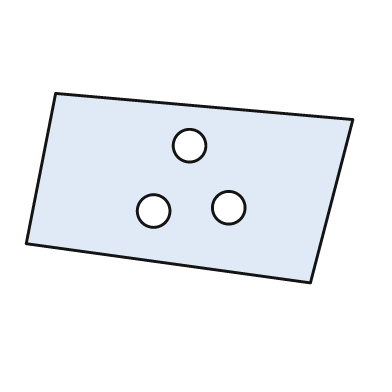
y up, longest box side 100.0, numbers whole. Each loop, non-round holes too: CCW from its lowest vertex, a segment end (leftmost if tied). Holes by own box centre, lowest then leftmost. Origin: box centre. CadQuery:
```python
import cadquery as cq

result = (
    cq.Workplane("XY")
    .moveTo(37.0, -29.0)
    .lineTo(50.0, 21.0)
    .lineTo(-41.0, 29.0)
    .lineTo(-50.0, -17.0)
    .close()
    .moveTo(-11.0, -7.0)
    .circle(5.0)
    .moveTo(12.0, -6.0)
    .circle(5.0)
    .moveTo(0.0, 13.0)
    .circle(5.0)
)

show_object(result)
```